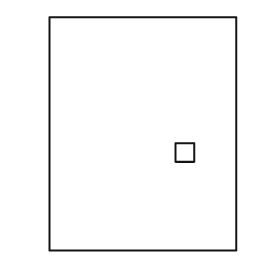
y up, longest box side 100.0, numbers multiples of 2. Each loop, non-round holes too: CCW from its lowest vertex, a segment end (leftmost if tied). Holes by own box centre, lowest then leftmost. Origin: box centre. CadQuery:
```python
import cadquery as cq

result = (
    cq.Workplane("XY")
    .moveTo(-40.0, -50.0)
    .lineTo(40.0, -50.0)
    .lineTo(40.0, 50.0)
    .lineTo(-40.0, 50.0)
    .close()
    .moveTo(14.0, -12.0)
    .lineTo(22.0, -12.0)
    .lineTo(22.0, -4.0)
    .lineTo(14.0, -4.0)
    .close()
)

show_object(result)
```